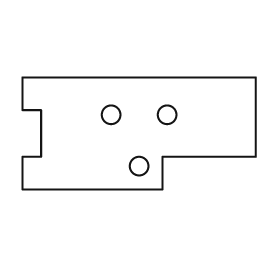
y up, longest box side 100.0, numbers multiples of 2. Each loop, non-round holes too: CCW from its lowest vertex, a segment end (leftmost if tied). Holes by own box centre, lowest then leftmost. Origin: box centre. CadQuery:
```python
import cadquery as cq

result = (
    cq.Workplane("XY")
    .moveTo(-50.0, -24.0)
    .lineTo(10.0, -24.0)
    .lineTo(10.0, -10.0)
    .lineTo(50.0, -10.0)
    .lineTo(50.0, 24.0)
    .lineTo(-50.0, 24.0)
    .lineTo(-50.0, 10.0)
    .lineTo(-42.0, 10.0)
    .lineTo(-42.0, -10.0)
    .lineTo(-50.0, -10.0)
    .close()
    .moveTo(0.0, -14.0)
    .circle(4.0)
    .moveTo(-12.0, 8.0)
    .circle(4.0)
    .moveTo(12.0, 8.0)
    .circle(4.0)
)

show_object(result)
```